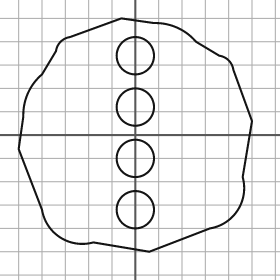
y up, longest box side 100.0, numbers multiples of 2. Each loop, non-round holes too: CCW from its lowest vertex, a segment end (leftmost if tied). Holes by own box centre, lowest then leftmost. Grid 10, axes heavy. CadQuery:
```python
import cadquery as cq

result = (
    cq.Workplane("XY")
    .moveTo(6.0, -50.0)
    .lineTo(32.0, -40.0)
    .threePointArc((44.0, -32.0), (46.0, -18.0))
    .lineTo(50.0, 6.0)
    .lineTo(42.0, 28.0)
    .threePointArc((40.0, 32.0), (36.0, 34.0))
    .lineTo(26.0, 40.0)
    .threePointArc((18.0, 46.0), (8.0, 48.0))
    .lineTo(-6.0, 50.0)
    .lineTo(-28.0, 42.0)
    .threePointArc((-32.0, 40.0), (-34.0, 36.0))
    .lineTo(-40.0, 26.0)
    .threePointArc((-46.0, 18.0), (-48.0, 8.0))
    .lineTo(-50.0, -6.0)
    .lineTo(-40.0, -32.0)
    .threePointArc((-32.0, -44.0), (-18.0, -46.0))
    .close()
    .moveTo(0.0, -32.0)
    .circle(8.0)
    .moveTo(0.0, -10.0)
    .circle(8.0)
    .moveTo(0.0, 12.0)
    .circle(8.0)
    .moveTo(0.0, 34.0)
    .circle(8.0)
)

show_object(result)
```